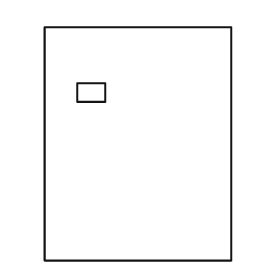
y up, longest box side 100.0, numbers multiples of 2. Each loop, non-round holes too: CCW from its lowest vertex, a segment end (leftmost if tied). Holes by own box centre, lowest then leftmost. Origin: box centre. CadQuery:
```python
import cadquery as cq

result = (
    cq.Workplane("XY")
    .moveTo(-40.0, -50.0)
    .lineTo(40.0, -50.0)
    .lineTo(40.0, 50.0)
    .lineTo(-40.0, 50.0)
    .close()
    .moveTo(-26.0, 18.0)
    .lineTo(-14.0, 18.0)
    .lineTo(-14.0, 26.0)
    .lineTo(-26.0, 26.0)
    .close()
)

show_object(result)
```